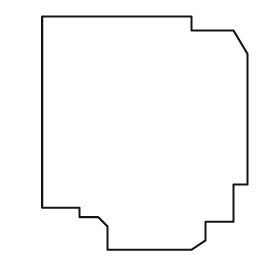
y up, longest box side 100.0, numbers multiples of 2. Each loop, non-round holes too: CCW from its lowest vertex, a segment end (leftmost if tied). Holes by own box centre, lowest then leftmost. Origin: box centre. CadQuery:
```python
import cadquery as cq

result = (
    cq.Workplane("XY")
    .moveTo(-16.0, -50.0)
    .lineTo(20.0, -50.0)
    .lineTo(26.0, -46.0)
    .lineTo(26.0, -38.0)
    .lineTo(38.0, -38.0)
    .lineTo(38.0, -22.0)
    .lineTo(44.0, -22.0)
    .lineTo(44.0, 34.0)
    .lineTo(38.0, 44.0)
    .lineTo(20.0, 44.0)
    .lineTo(20.0, 50.0)
    .lineTo(-44.0, 50.0)
    .lineTo(-44.0, -32.0)
    .lineTo(-28.0, -32.0)
    .lineTo(-28.0, -36.0)
    .lineTo(-20.0, -36.0)
    .lineTo(-16.0, -40.0)
    .close()
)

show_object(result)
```